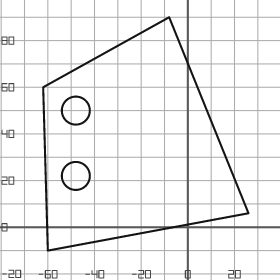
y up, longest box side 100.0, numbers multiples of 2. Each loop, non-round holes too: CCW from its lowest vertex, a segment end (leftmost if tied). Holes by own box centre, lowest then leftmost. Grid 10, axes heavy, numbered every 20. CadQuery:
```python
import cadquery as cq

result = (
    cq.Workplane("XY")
    .moveTo(-60.0, -10.0)
    .lineTo(26.0, 6.0)
    .lineTo(-8.0, 90.0)
    .lineTo(-62.0, 60.0)
    .close()
    .moveTo(-48.0, 22.0)
    .circle(6.0)
    .moveTo(-48.0, 50.0)
    .circle(6.0)
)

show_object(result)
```